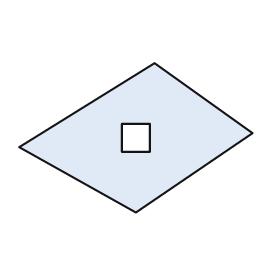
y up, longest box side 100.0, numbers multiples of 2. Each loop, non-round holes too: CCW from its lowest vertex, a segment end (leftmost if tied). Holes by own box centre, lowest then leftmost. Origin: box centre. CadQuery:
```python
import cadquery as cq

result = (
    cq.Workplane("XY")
    .moveTo(0.0, -32.0)
    .lineTo(50.0, 2.0)
    .lineTo(8.0, 32.0)
    .lineTo(-50.0, -4.0)
    .close()
    .moveTo(-6.0, -6.0)
    .lineTo(6.0, -6.0)
    .lineTo(6.0, 6.0)
    .lineTo(-6.0, 6.0)
    .close()
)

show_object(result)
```